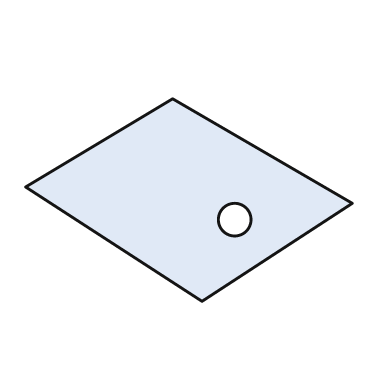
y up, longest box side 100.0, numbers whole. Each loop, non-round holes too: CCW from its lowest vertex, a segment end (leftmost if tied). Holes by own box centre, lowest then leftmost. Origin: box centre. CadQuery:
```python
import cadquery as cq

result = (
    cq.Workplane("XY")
    .moveTo(4.0, -31.0)
    .lineTo(50.0, -1.0)
    .lineTo(-5.0, 31.0)
    .lineTo(-50.0, 4.0)
    .close()
    .moveTo(14.0, -6.0)
    .circle(5.0)
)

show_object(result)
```